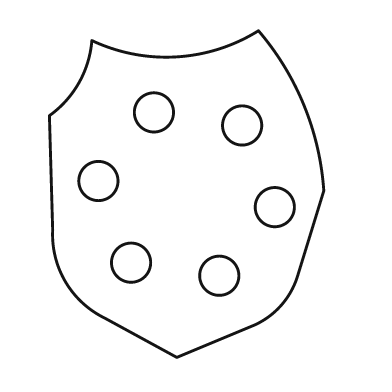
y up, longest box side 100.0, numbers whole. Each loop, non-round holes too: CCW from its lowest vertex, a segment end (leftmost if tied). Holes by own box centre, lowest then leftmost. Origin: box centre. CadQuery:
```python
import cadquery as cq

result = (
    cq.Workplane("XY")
    .moveTo(-3.0, -50.0)
    .lineTo(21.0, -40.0)
    .threePointArc((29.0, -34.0), (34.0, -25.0))
    .lineTo(42.0, 1.0)
    .threePointArc((36.0, 27.0), (22.0, 50.0))
    .threePointArc((-3.0, 42.0), (-29.0, 47.0))
    .threePointArc((-33.0, 34.0), (-42.0, 24.0))
    .lineTo(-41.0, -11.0)
    .threePointArc((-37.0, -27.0), (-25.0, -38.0))
    .close()
    .moveTo(10.0, -25.0)
    .circle(6.0)
    .moveTo(-17.0, -21.0)
    .circle(6.0)
    .moveTo(27.0, -4.0)
    .circle(6.0)
    .moveTo(-27.0, 4.0)
    .circle(6.0)
    .moveTo(17.0, 21.0)
    .circle(6.0)
    .moveTo(-10.0, 25.0)
    .circle(6.0)
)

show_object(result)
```